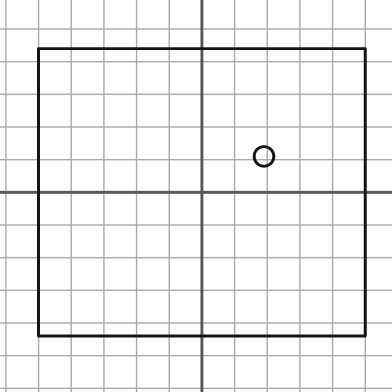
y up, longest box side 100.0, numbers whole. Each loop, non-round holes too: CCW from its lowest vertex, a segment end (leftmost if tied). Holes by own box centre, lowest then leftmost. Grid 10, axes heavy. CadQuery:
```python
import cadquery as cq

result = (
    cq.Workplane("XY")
    .moveTo(-50.0, -44.0)
    .lineTo(50.0, -44.0)
    .lineTo(50.0, 44.0)
    .lineTo(-50.0, 44.0)
    .close()
    .moveTo(19.0, 11.0)
    .circle(3.0)
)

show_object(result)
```